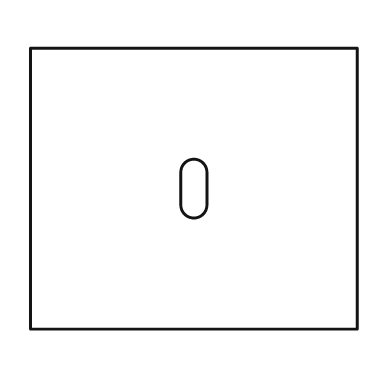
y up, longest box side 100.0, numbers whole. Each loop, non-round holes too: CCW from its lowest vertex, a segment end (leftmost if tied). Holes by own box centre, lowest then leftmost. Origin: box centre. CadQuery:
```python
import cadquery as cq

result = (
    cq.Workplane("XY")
    .moveTo(-50.0, -43.0)
    .lineTo(50.0, -43.0)
    .lineTo(50.0, 43.0)
    .lineTo(-50.0, 43.0)
    .close()
    .moveTo(-4.0, -5.0)
    .threePointArc((0.0, -9.0), (4.0, -5.0))
    .lineTo(4.0, 5.0)
    .threePointArc((0.0, 9.0), (-4.0, 5.0))
    .close()
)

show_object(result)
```